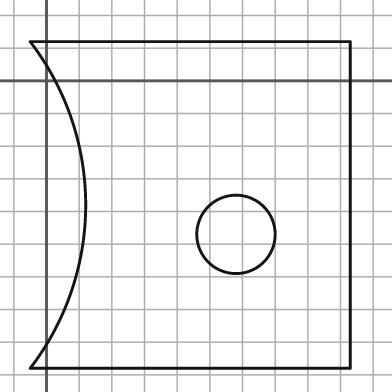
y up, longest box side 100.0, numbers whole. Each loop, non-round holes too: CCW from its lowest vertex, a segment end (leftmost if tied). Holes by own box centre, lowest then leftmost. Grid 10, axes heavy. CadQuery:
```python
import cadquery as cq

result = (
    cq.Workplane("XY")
    .moveTo(-5.0, -88.0)
    .lineTo(93.0, -88.0)
    .lineTo(93.0, 12.0)
    .lineTo(-5.0, 12.0)
    .threePointArc((12.0, -38.0), (-5.0, -88.0))
    .close()
    .moveTo(58.0, -47.0)
    .circle(12.0)
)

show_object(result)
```